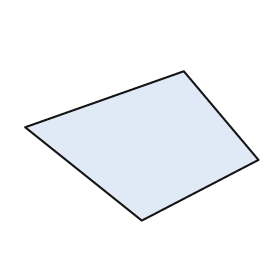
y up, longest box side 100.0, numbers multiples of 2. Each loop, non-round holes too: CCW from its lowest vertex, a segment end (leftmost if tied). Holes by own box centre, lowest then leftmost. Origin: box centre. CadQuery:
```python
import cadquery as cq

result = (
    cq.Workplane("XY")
    .moveTo(0.0, -32.0)
    .lineTo(50.0, -6.0)
    .lineTo(18.0, 32.0)
    .lineTo(-50.0, 8.0)
    .close()
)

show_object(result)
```